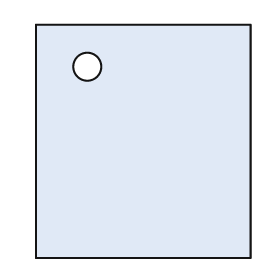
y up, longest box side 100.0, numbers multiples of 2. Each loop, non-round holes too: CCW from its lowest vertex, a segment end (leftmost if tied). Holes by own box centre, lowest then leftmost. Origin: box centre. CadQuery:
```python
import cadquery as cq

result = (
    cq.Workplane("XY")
    .moveTo(-46.0, -50.0)
    .lineTo(46.0, -50.0)
    .lineTo(46.0, 50.0)
    .lineTo(-46.0, 50.0)
    .close()
    .moveTo(-24.0, 32.0)
    .circle(6.0)
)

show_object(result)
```